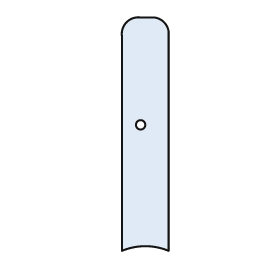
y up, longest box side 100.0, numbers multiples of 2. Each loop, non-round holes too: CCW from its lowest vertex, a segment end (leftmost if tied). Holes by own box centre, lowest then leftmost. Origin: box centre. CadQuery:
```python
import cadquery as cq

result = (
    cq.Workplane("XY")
    .moveTo(-10.0, -50.0)
    .threePointArc((0.0, -48.0), (10.0, -50.0))
    .lineTo(10.0, 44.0)
    .threePointArc((8.0, 48.0), (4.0, 50.0))
    .lineTo(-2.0, 50.0)
    .threePointArc((-8.0, 48.0), (-10.0, 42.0))
    .close()
    .moveTo(-2.0, 4.0)
    .circle(2.0)
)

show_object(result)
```